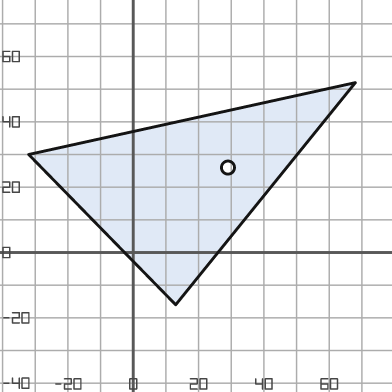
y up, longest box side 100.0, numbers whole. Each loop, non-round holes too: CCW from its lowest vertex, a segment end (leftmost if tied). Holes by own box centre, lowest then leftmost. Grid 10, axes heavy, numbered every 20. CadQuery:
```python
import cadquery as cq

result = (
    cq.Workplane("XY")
    .moveTo(13.0, -16.0)
    .lineTo(68.0, 52.0)
    .lineTo(-32.0, 30.0)
    .close()
    .moveTo(29.0, 26.0)
    .circle(2.0)
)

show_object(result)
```